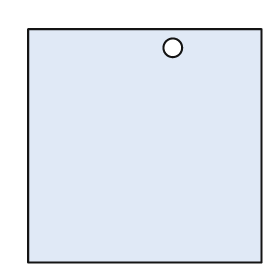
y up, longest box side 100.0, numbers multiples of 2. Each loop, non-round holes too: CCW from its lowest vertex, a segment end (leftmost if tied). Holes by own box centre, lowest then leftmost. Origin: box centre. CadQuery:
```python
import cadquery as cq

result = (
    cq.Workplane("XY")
    .moveTo(-50.0, -50.0)
    .lineTo(50.0, -50.0)
    .lineTo(50.0, 50.0)
    .lineTo(-50.0, 50.0)
    .close()
    .moveTo(12.0, 42.0)
    .circle(4.0)
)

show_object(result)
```